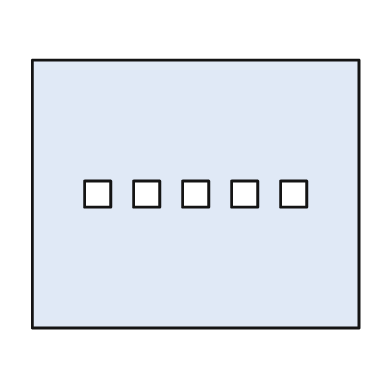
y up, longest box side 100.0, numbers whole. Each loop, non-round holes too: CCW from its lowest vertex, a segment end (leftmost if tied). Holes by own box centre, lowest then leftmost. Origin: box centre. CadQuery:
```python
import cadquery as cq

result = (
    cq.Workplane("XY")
    .moveTo(-50.0, -41.0)
    .lineTo(50.0, -41.0)
    .lineTo(50.0, 41.0)
    .lineTo(-50.0, 41.0)
    .close()
    .moveTo(-34.0, -4.0)
    .lineTo(-26.0, -4.0)
    .lineTo(-26.0, 4.0)
    .lineTo(-34.0, 4.0)
    .close()
    .moveTo(-19.0, -4.0)
    .lineTo(-11.0, -4.0)
    .lineTo(-11.0, 4.0)
    .lineTo(-19.0, 4.0)
    .close()
    .moveTo(-4.0, -4.0)
    .lineTo(4.0, -4.0)
    .lineTo(4.0, 4.0)
    .lineTo(-4.0, 4.0)
    .close()
    .moveTo(11.0, -4.0)
    .lineTo(19.0, -4.0)
    .lineTo(19.0, 4.0)
    .lineTo(11.0, 4.0)
    .close()
    .moveTo(26.0, -4.0)
    .lineTo(34.0, -4.0)
    .lineTo(34.0, 4.0)
    .lineTo(26.0, 4.0)
    .close()
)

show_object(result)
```